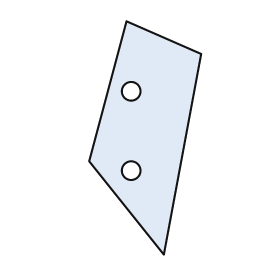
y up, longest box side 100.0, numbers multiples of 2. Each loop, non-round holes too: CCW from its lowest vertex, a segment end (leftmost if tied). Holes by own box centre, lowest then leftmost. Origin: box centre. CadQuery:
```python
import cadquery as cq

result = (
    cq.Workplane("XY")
    .moveTo(8.0, -50.0)
    .lineTo(24.0, 36.0)
    .lineTo(-8.0, 50.0)
    .lineTo(-24.0, -10.0)
    .close()
    .moveTo(-6.0, -14.0)
    .circle(4.0)
    .moveTo(-6.0, 20.0)
    .circle(4.0)
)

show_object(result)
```